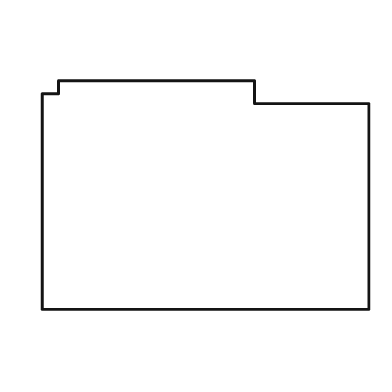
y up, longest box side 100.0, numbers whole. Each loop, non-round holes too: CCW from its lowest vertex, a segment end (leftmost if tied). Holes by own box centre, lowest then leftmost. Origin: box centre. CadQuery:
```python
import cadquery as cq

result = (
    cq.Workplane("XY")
    .moveTo(-50.0, -35.0)
    .lineTo(50.0, -35.0)
    .lineTo(50.0, 28.0)
    .lineTo(15.0, 28.0)
    .lineTo(15.0, 35.0)
    .lineTo(-45.0, 35.0)
    .lineTo(-45.0, 31.0)
    .lineTo(-50.0, 31.0)
    .close()
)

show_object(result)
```